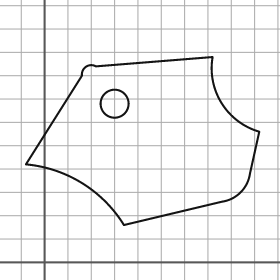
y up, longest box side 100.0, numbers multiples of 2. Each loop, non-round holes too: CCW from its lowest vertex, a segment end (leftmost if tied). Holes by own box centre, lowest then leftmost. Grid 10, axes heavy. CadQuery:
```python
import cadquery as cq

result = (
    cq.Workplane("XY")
    .moveTo(34.0, 16.0)
    .lineTo(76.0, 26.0)
    .threePointArc((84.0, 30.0), (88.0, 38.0))
    .lineTo(92.0, 56.0)
    .threePointArc((76.0, 68.0), (72.0, 88.0))
    .lineTo(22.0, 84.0)
    .threePointArc((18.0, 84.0), (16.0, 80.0))
    .lineTo(-8.0, 42.0)
    .threePointArc((16.0, 34.0), (34.0, 16.0))
    .close()
    .moveTo(30.0, 68.0)
    .circle(6.0)
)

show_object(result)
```